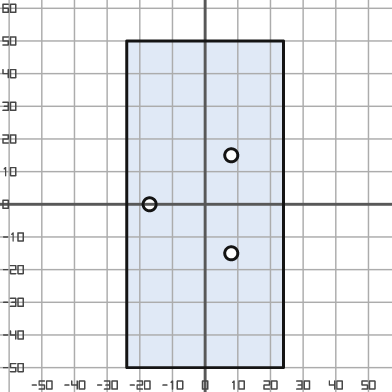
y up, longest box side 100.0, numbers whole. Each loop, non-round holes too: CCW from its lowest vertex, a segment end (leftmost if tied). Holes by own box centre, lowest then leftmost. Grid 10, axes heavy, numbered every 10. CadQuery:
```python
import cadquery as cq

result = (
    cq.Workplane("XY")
    .moveTo(-24.0, -50.0)
    .lineTo(24.0, -50.0)
    .lineTo(24.0, 50.0)
    .lineTo(-24.0, 50.0)
    .close()
    .moveTo(8.0, -15.0)
    .circle(2.0)
    .moveTo(-17.0, 0.0)
    .circle(2.0)
    .moveTo(8.0, 15.0)
    .circle(2.0)
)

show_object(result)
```